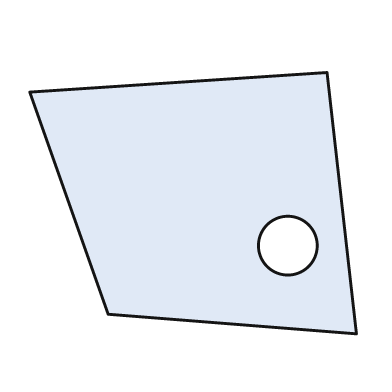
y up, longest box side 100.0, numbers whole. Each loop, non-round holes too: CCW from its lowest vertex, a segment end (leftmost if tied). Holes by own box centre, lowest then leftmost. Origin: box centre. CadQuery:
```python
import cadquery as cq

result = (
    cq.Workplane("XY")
    .moveTo(50.0, -40.0)
    .lineTo(41.0, 40.0)
    .lineTo(-50.0, 34.0)
    .lineTo(-26.0, -34.0)
    .close()
    .moveTo(29.0, -13.0)
    .circle(9.0)
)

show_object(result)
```